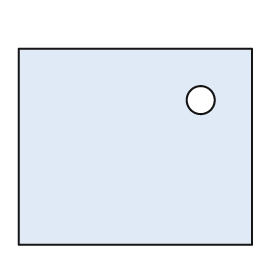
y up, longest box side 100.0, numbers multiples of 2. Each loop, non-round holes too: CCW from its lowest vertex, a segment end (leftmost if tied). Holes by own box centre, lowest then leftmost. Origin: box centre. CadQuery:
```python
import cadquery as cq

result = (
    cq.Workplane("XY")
    .moveTo(-50.0, -42.0)
    .lineTo(50.0, -42.0)
    .lineTo(50.0, 42.0)
    .lineTo(-50.0, 42.0)
    .close()
    .moveTo(28.0, 20.0)
    .circle(6.0)
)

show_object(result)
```